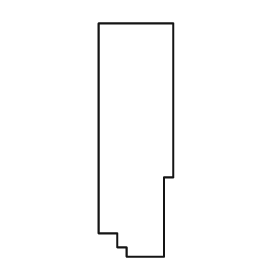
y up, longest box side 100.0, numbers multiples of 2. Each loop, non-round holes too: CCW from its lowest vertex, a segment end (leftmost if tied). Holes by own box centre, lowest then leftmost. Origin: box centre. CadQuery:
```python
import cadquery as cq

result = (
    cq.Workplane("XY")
    .moveTo(-4.0, -50.0)
    .lineTo(12.0, -50.0)
    .lineTo(12.0, -16.0)
    .lineTo(16.0, -16.0)
    .lineTo(16.0, 50.0)
    .lineTo(-16.0, 50.0)
    .lineTo(-16.0, -40.0)
    .lineTo(-8.0, -40.0)
    .lineTo(-8.0, -46.0)
    .lineTo(-4.0, -46.0)
    .close()
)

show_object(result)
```